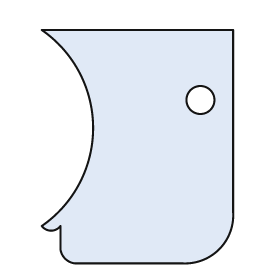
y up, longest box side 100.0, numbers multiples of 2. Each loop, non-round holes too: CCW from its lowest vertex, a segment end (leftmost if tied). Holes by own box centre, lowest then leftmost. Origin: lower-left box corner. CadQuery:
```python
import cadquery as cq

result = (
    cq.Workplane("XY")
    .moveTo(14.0, 0.0)
    .lineTo(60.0, 0.0)
    .threePointArc((76.0, 6.0), (82.0, 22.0))
    .lineTo(82.0, 100.0)
    .lineTo(0.0, 100.0)
    .threePointArc((22.0, 58.0), (0.0, 16.0))
    .threePointArc((4.0, 14.0), (8.0, 16.0))
    .lineTo(8.0, 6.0)
    .threePointArc((10.0, 2.0), (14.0, 0.0))
    .close()
    .moveTo(68.0, 70.0)
    .circle(6.0)
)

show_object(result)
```